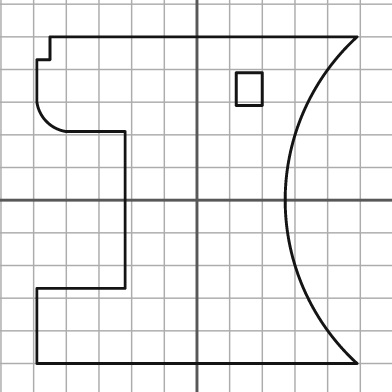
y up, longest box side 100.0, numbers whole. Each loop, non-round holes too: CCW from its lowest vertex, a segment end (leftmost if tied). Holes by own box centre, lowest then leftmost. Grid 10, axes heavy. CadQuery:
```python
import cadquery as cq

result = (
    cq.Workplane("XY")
    .moveTo(-49.0, -50.0)
    .lineTo(49.0, -50.0)
    .threePointArc((27.0, 0.0), (49.0, 50.0))
    .lineTo(-45.0, 50.0)
    .lineTo(-45.0, 43.0)
    .lineTo(-49.0, 43.0)
    .lineTo(-49.0, 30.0)
    .threePointArc((-46.0, 24.0), (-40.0, 21.0))
    .lineTo(-22.0, 21.0)
    .lineTo(-22.0, -27.0)
    .lineTo(-49.0, -27.0)
    .close()
    .moveTo(12.0, 29.0)
    .lineTo(20.0, 29.0)
    .lineTo(20.0, 39.0)
    .lineTo(12.0, 39.0)
    .close()
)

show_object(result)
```